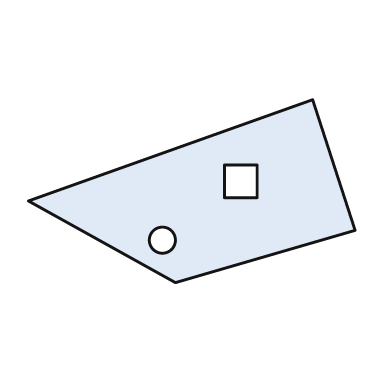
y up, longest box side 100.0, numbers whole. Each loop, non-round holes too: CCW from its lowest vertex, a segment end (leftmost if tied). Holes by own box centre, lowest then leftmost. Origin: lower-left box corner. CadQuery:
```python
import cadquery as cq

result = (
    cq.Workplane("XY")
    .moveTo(45.0, 0.0)
    .lineTo(100.0, 16.0)
    .lineTo(87.0, 56.0)
    .lineTo(0.0, 25.0)
    .close()
    .moveTo(41.0, 13.0)
    .circle(4.0)
    .moveTo(60.0, 26.0)
    .lineTo(70.0, 26.0)
    .lineTo(70.0, 36.0)
    .lineTo(60.0, 36.0)
    .close()
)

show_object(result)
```